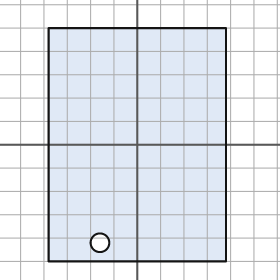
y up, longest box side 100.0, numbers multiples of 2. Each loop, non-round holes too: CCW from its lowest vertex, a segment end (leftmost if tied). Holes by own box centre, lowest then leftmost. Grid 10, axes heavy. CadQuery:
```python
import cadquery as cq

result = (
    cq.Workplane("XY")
    .moveTo(-38.0, -50.0)
    .lineTo(38.0, -50.0)
    .lineTo(38.0, 50.0)
    .lineTo(-38.0, 50.0)
    .close()
    .moveTo(-16.0, -42.0)
    .circle(4.0)
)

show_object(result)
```